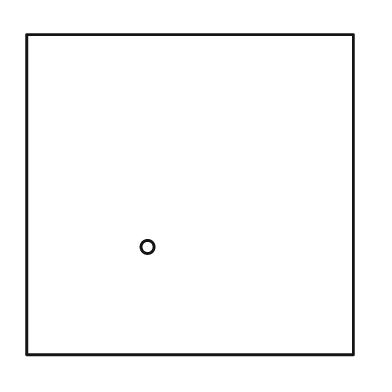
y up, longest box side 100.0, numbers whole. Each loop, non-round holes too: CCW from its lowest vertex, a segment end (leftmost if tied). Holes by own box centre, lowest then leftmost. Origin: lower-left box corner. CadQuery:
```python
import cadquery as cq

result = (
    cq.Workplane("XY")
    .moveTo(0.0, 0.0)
    .lineTo(100.0, 0.0)
    .lineTo(100.0, 98.0)
    .lineTo(0.0, 98.0)
    .close()
    .moveTo(37.0, 33.0)
    .circle(2.0)
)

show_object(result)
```